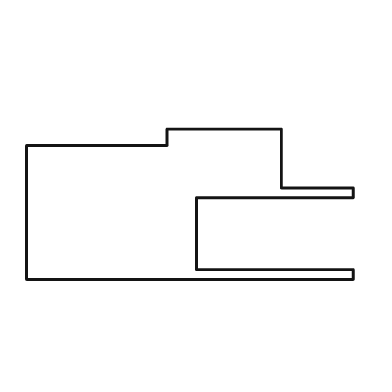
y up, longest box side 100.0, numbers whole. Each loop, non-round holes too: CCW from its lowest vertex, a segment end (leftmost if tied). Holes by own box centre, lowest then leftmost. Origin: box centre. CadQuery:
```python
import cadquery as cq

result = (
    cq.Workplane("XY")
    .moveTo(-50.0, -23.0)
    .lineTo(50.0, -23.0)
    .lineTo(50.0, -20.0)
    .lineTo(2.0, -20.0)
    .lineTo(2.0, 2.0)
    .lineTo(50.0, 2.0)
    .lineTo(50.0, 5.0)
    .lineTo(28.0, 5.0)
    .lineTo(28.0, 23.0)
    .lineTo(-7.0, 23.0)
    .lineTo(-7.0, 18.0)
    .lineTo(-50.0, 18.0)
    .close()
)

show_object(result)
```